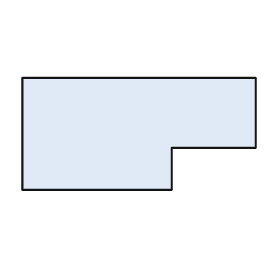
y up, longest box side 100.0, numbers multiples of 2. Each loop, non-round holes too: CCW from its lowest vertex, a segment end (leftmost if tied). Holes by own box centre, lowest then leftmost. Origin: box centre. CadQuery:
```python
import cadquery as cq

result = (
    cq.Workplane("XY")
    .moveTo(-50.0, -24.0)
    .lineTo(14.0, -24.0)
    .lineTo(14.0, -6.0)
    .lineTo(50.0, -6.0)
    .lineTo(50.0, 24.0)
    .lineTo(-50.0, 24.0)
    .close()
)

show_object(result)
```